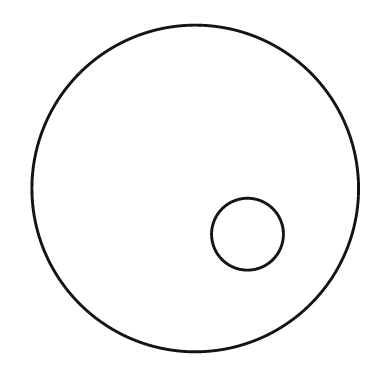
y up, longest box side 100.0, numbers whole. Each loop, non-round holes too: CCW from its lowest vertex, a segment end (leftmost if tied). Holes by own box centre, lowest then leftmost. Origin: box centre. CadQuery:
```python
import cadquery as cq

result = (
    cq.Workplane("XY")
    .moveTo(0.0, 0.0)
    .circle(50.0)
    .moveTo(16.0, -14.0)
    .circle(11.0)
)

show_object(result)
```